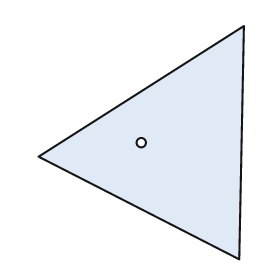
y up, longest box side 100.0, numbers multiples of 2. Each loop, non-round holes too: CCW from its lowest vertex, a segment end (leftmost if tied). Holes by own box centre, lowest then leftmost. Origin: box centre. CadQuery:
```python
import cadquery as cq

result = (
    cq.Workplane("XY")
    .moveTo(42.0, -50.0)
    .lineTo(44.0, 50.0)
    .lineTo(-44.0, -6.0)
    .close()
    .moveTo(0.0, 0.0)
    .circle(2.0)
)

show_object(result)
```